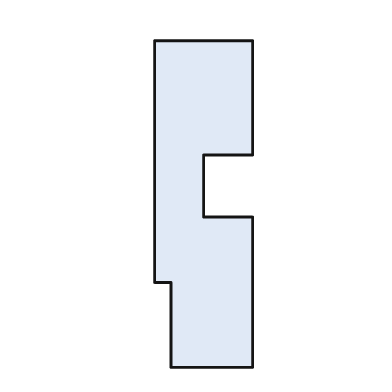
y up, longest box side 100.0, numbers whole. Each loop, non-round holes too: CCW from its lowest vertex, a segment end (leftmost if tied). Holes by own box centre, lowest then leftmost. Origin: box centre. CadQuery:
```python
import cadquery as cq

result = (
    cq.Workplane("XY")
    .moveTo(-10.0, -50.0)
    .lineTo(15.0, -50.0)
    .lineTo(15.0, -4.0)
    .lineTo(0.0, -4.0)
    .lineTo(0.0, 15.0)
    .lineTo(15.0, 15.0)
    .lineTo(15.0, 50.0)
    .lineTo(-15.0, 50.0)
    .lineTo(-15.0, -24.0)
    .lineTo(-10.0, -24.0)
    .close()
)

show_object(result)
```